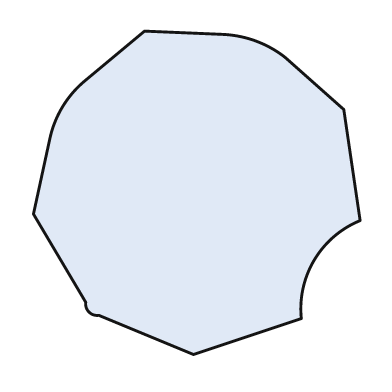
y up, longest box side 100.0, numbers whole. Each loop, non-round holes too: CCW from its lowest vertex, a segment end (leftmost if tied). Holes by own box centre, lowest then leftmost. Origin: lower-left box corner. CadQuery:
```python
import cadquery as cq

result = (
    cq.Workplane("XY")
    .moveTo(49.0, 0.0)
    .lineTo(82.0, 11.0)
    .threePointArc((86.0, 29.0), (100.0, 41.0))
    .lineTo(95.0, 75.0)
    .lineTo(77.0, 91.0)
    .threePointArc((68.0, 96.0), (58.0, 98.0))
    .lineTo(34.0, 99.0)
    .lineTo(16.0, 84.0)
    .threePointArc((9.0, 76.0), (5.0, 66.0))
    .lineTo(0.0, 43.0)
    .lineTo(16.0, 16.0)
    .threePointArc((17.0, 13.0), (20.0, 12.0))
    .close()
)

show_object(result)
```